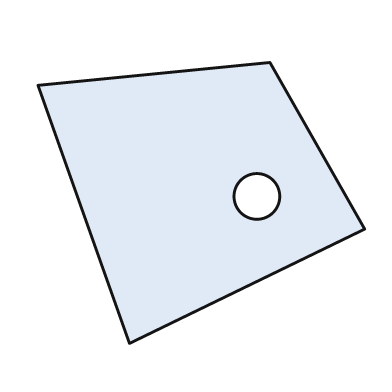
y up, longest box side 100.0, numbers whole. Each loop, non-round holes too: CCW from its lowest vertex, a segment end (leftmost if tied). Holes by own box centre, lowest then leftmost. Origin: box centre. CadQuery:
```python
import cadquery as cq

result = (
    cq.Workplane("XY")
    .moveTo(-22.0, -43.0)
    .lineTo(50.0, -8.0)
    .lineTo(21.0, 43.0)
    .lineTo(-50.0, 36.0)
    .close()
    .moveTo(17.0, 2.0)
    .circle(7.0)
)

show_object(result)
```